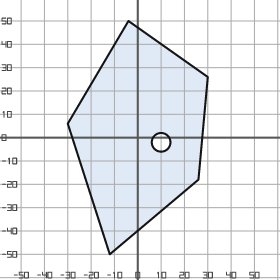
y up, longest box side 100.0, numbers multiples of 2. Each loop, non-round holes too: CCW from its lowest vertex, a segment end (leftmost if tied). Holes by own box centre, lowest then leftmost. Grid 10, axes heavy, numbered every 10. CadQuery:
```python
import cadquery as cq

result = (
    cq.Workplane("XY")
    .moveTo(-12.0, -50.0)
    .lineTo(26.0, -18.0)
    .lineTo(30.0, 26.0)
    .lineTo(-4.0, 50.0)
    .lineTo(-30.0, 6.0)
    .close()
    .moveTo(10.0, -2.0)
    .circle(4.0)
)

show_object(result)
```